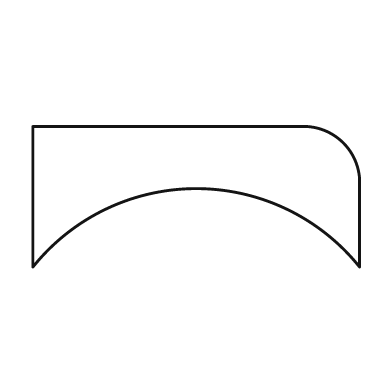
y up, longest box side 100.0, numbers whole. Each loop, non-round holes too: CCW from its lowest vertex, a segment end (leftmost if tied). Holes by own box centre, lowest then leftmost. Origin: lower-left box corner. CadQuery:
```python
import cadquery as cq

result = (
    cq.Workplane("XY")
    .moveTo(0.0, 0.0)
    .threePointArc((50.0, 24.0), (100.0, 0.0))
    .lineTo(100.0, 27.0)
    .threePointArc((95.0, 38.0), (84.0, 43.0))
    .lineTo(0.0, 43.0)
    .close()
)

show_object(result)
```